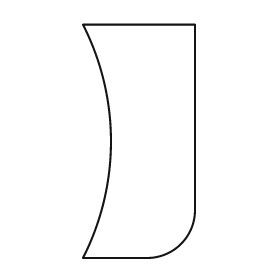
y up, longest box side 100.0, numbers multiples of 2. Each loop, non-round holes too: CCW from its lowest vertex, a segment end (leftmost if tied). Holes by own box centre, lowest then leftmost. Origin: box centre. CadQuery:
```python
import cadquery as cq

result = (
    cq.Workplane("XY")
    .moveTo(-24.0, -50.0)
    .lineTo(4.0, -50.0)
    .threePointArc((18.0, -44.0), (24.0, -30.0))
    .lineTo(24.0, 50.0)
    .lineTo(-24.0, 50.0)
    .threePointArc((-12.0, 0.0), (-24.0, -50.0))
    .close()
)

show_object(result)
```